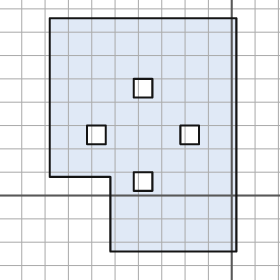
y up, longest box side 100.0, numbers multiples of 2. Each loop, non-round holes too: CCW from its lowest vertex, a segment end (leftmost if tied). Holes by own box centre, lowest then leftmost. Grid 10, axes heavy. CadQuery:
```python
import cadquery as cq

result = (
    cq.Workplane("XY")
    .moveTo(-52.0, -24.0)
    .lineTo(2.0, -24.0)
    .lineTo(2.0, 76.0)
    .lineTo(-78.0, 76.0)
    .lineTo(-78.0, 8.0)
    .lineTo(-52.0, 8.0)
    .close()
    .moveTo(-42.0, 2.0)
    .lineTo(-34.0, 2.0)
    .lineTo(-34.0, 10.0)
    .lineTo(-42.0, 10.0)
    .close()
    .moveTo(-62.0, 22.0)
    .lineTo(-54.0, 22.0)
    .lineTo(-54.0, 30.0)
    .lineTo(-62.0, 30.0)
    .close()
    .moveTo(-22.0, 22.0)
    .lineTo(-14.0, 22.0)
    .lineTo(-14.0, 30.0)
    .lineTo(-22.0, 30.0)
    .close()
    .moveTo(-42.0, 42.0)
    .lineTo(-34.0, 42.0)
    .lineTo(-34.0, 50.0)
    .lineTo(-42.0, 50.0)
    .close()
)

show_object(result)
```